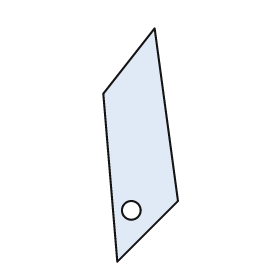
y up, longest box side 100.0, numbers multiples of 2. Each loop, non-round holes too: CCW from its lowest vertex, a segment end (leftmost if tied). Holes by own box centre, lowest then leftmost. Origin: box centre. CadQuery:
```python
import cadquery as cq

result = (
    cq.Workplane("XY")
    .moveTo(-10.0, -50.0)
    .lineTo(16.0, -24.0)
    .lineTo(6.0, 50.0)
    .lineTo(-16.0, 22.0)
    .close()
    .moveTo(-4.0, -28.0)
    .circle(4.0)
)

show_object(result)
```